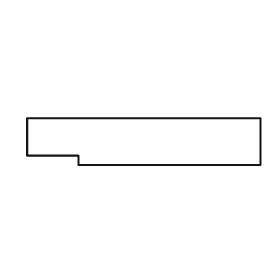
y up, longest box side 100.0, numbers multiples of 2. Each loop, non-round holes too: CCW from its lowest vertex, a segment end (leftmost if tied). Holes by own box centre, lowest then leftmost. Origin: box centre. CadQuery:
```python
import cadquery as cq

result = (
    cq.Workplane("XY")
    .moveTo(-28.0, -10.0)
    .lineTo(50.0, -10.0)
    .lineTo(50.0, 10.0)
    .lineTo(-50.0, 10.0)
    .lineTo(-50.0, -6.0)
    .lineTo(-28.0, -6.0)
    .close()
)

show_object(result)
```